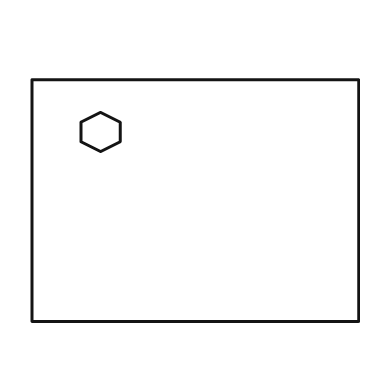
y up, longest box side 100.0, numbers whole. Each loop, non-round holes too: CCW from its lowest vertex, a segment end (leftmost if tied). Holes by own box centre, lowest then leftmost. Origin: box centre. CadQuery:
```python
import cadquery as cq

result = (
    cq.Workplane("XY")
    .moveTo(-50.0, -37.0)
    .lineTo(50.0, -37.0)
    .lineTo(50.0, 37.0)
    .lineTo(-50.0, 37.0)
    .close()
    .moveTo(-29.0, 15.0)
    .lineTo(-23.0, 18.0)
    .lineTo(-23.0, 24.0)
    .lineTo(-29.0, 27.0)
    .lineTo(-35.0, 24.0)
    .lineTo(-35.0, 18.0)
    .close()
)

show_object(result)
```